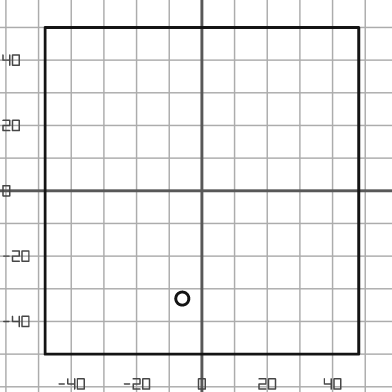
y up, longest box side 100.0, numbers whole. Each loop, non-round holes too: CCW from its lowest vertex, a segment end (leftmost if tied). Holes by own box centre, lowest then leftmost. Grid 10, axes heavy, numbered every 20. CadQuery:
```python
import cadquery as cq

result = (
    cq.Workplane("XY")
    .moveTo(-48.0, -50.0)
    .lineTo(48.0, -50.0)
    .lineTo(48.0, 50.0)
    .lineTo(-48.0, 50.0)
    .close()
    .moveTo(-6.0, -33.0)
    .circle(2.0)
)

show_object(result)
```